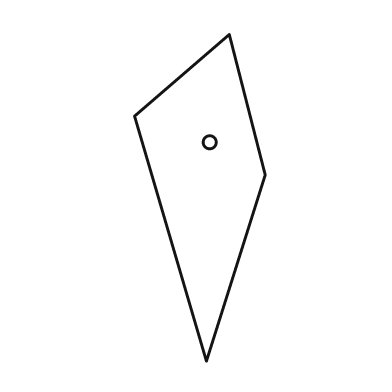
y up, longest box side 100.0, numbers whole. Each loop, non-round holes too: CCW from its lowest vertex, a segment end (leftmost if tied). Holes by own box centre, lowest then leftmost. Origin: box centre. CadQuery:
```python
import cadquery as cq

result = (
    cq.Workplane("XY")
    .moveTo(2.0, -50.0)
    .lineTo(20.0, 7.0)
    .lineTo(9.0, 50.0)
    .lineTo(-20.0, 25.0)
    .close()
    .moveTo(3.0, 17.0)
    .circle(2.0)
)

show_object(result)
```